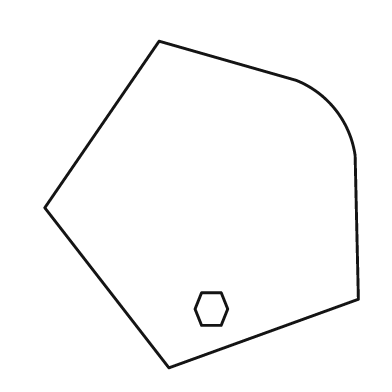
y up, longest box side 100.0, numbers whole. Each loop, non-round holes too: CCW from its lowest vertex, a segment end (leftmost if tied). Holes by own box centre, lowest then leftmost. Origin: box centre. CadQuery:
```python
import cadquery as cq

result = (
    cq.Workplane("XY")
    .moveTo(-10.0, -50.0)
    .lineTo(48.0, -29.0)
    .lineTo(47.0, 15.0)
    .threePointArc((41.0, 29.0), (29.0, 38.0))
    .lineTo(-13.0, 50.0)
    .lineTo(-48.0, -1.0)
    .close()
    .moveTo(0.0, -37.0)
    .lineTo(6.0, -37.0)
    .lineTo(8.0, -32.0)
    .lineTo(6.0, -27.0)
    .lineTo(0.0, -27.0)
    .lineTo(-2.0, -32.0)
    .close()
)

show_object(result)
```